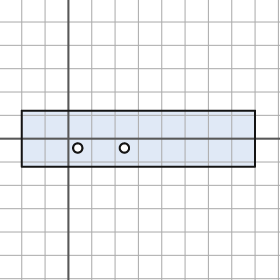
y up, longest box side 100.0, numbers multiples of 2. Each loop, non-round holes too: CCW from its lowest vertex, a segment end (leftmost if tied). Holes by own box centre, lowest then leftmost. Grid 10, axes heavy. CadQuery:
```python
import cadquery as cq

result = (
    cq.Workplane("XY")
    .moveTo(-20.0, -12.0)
    .lineTo(80.0, -12.0)
    .lineTo(80.0, 12.0)
    .lineTo(-20.0, 12.0)
    .close()
    .moveTo(4.0, -4.0)
    .circle(2.0)
    .moveTo(24.0, -4.0)
    .circle(2.0)
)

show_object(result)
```